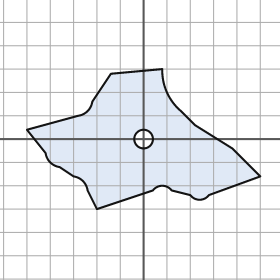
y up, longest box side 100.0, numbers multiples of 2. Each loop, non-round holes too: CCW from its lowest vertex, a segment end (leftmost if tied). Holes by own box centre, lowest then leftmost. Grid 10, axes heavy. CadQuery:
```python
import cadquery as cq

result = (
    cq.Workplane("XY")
    .moveTo(-20.0, -30.0)
    .lineTo(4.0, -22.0)
    .threePointArc((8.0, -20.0), (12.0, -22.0))
    .lineTo(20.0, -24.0)
    .threePointArc((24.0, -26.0), (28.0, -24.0))
    .lineTo(50.0, -16.0)
    .lineTo(38.0, -4.0)
    .lineTo(22.0, 6.0)
    .lineTo(16.0, 12.0)
    .threePointArc((10.0, 20.0), (8.0, 30.0))
    .lineTo(-14.0, 28.0)
    .lineTo(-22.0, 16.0)
    .threePointArc((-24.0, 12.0), (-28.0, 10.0))
    .lineTo(-50.0, 4.0)
    .lineTo(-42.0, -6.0)
    .threePointArc((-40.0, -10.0), (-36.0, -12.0))
    .lineTo(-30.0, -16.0)
    .threePointArc((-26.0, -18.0), (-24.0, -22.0))
    .close()
    .moveTo(0.0, 0.0)
    .circle(4.0)
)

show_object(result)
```